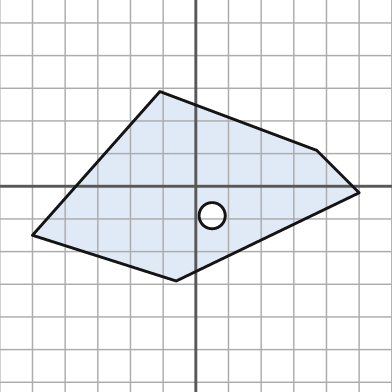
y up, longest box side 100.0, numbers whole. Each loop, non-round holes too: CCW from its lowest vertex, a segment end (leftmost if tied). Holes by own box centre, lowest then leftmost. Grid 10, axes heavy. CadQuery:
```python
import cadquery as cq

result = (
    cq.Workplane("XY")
    .moveTo(-6.0, -29.0)
    .lineTo(50.0, -2.0)
    .lineTo(37.0, 11.0)
    .lineTo(-11.0, 29.0)
    .lineTo(-50.0, -15.0)
    .close()
    .moveTo(5.0, -9.0)
    .circle(4.0)
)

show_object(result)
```